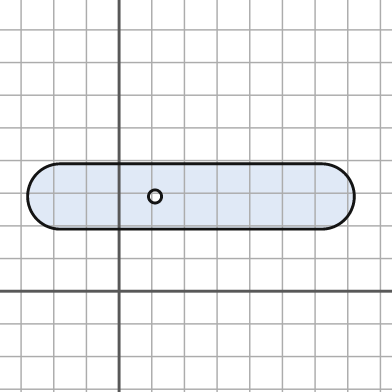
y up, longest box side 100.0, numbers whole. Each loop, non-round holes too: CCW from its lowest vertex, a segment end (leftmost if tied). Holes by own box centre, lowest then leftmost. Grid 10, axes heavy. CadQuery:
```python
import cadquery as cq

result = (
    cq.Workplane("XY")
    .moveTo(-18.0, 19.0)
    .lineTo(62.0, 19.0)
    .threePointArc((72.0, 29.0), (62.0, 39.0))
    .lineTo(-18.0, 39.0)
    .threePointArc((-28.0, 29.0), (-18.0, 19.0))
    .close()
    .moveTo(11.0, 29.0)
    .circle(2.0)
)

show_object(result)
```